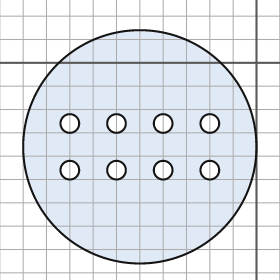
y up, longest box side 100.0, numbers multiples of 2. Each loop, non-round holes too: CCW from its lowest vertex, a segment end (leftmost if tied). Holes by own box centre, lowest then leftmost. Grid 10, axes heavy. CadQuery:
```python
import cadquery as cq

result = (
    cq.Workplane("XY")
    .moveTo(-50.0, -36.0)
    .circle(50.0)
    .moveTo(-80.0, -46.0)
    .circle(4.0)
    .moveTo(-60.0, -46.0)
    .circle(4.0)
    .moveTo(-40.0, -46.0)
    .circle(4.0)
    .moveTo(-20.0, -46.0)
    .circle(4.0)
    .moveTo(-80.0, -26.0)
    .circle(4.0)
    .moveTo(-60.0, -26.0)
    .circle(4.0)
    .moveTo(-40.0, -26.0)
    .circle(4.0)
    .moveTo(-20.0, -26.0)
    .circle(4.0)
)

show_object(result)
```